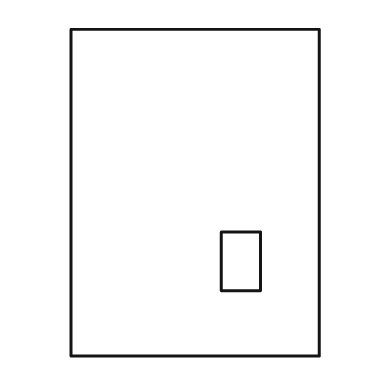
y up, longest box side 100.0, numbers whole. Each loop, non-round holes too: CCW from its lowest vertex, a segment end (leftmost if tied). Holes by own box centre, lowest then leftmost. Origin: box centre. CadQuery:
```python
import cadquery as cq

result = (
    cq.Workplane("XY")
    .moveTo(-38.0, -50.0)
    .lineTo(38.0, -50.0)
    .lineTo(38.0, 50.0)
    .lineTo(-38.0, 50.0)
    .close()
    .moveTo(8.0, -30.0)
    .lineTo(20.0, -30.0)
    .lineTo(20.0, -12.0)
    .lineTo(8.0, -12.0)
    .close()
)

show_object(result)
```